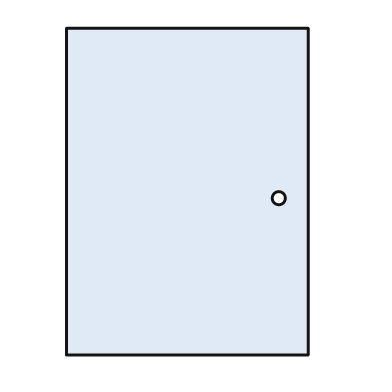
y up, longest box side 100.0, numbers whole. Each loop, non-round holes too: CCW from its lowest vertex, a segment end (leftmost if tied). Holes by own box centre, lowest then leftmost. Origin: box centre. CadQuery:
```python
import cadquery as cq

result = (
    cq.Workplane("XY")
    .moveTo(-37.0, -50.0)
    .lineTo(37.0, -50.0)
    .lineTo(37.0, 50.0)
    .lineTo(-37.0, 50.0)
    .close()
    .moveTo(28.0, -2.0)
    .circle(2.0)
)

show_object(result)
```